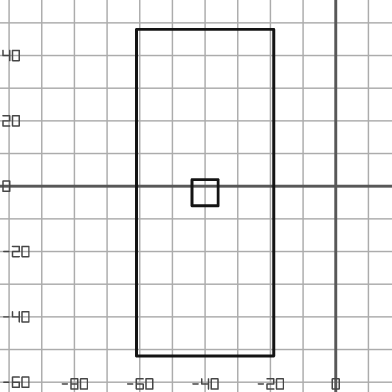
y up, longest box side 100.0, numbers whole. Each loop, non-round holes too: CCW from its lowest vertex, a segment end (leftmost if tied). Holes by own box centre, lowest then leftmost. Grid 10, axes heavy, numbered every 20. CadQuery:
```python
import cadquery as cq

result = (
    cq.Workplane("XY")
    .moveTo(-61.0, -52.0)
    .lineTo(-19.0, -52.0)
    .lineTo(-19.0, 48.0)
    .lineTo(-61.0, 48.0)
    .close()
    .moveTo(-44.0, -6.0)
    .lineTo(-36.0, -6.0)
    .lineTo(-36.0, 2.0)
    .lineTo(-44.0, 2.0)
    .close()
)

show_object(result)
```